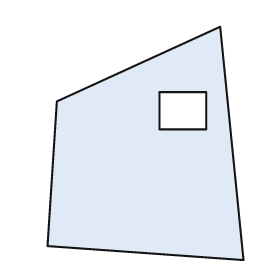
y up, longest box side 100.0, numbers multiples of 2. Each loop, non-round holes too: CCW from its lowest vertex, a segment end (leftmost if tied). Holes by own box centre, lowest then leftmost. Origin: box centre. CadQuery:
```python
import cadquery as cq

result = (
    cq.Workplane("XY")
    .moveTo(42.0, -50.0)
    .lineTo(32.0, 50.0)
    .lineTo(-38.0, 18.0)
    .lineTo(-42.0, -44.0)
    .close()
    .moveTo(6.0, 6.0)
    .lineTo(26.0, 6.0)
    .lineTo(26.0, 22.0)
    .lineTo(6.0, 22.0)
    .close()
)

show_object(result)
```